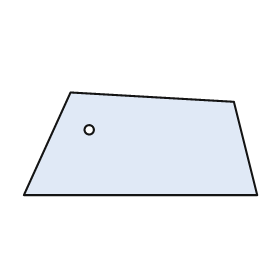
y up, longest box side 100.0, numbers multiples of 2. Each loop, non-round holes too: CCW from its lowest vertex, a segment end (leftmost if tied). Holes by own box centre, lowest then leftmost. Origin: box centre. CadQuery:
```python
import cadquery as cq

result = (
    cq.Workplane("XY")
    .moveTo(-50.0, -22.0)
    .lineTo(50.0, -22.0)
    .lineTo(40.0, 18.0)
    .lineTo(-30.0, 22.0)
    .close()
    .moveTo(-22.0, 6.0)
    .circle(2.0)
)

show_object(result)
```